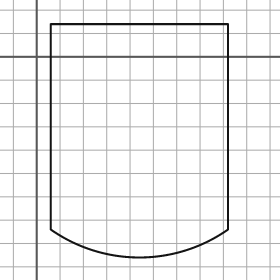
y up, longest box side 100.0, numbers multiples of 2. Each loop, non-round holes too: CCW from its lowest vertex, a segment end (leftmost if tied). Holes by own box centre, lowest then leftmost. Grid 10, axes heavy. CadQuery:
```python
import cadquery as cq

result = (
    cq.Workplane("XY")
    .moveTo(6.0, -74.0)
    .threePointArc((44.0, -86.0), (82.0, -74.0))
    .lineTo(82.0, 14.0)
    .lineTo(6.0, 14.0)
    .close()
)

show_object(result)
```